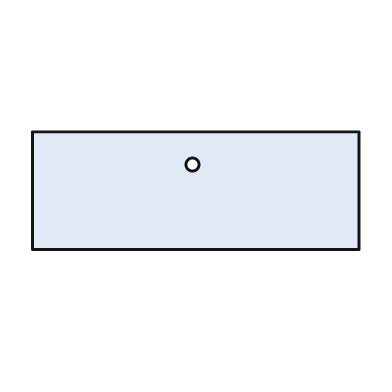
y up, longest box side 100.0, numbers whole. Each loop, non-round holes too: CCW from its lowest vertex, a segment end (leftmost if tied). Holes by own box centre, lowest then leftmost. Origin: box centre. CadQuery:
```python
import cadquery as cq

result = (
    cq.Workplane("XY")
    .moveTo(-50.0, -18.0)
    .lineTo(50.0, -18.0)
    .lineTo(50.0, 18.0)
    .lineTo(-50.0, 18.0)
    .close()
    .moveTo(-1.0, 8.0)
    .circle(2.0)
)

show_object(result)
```